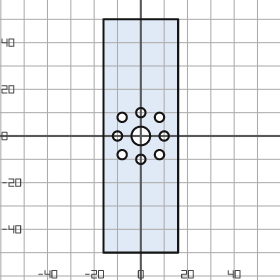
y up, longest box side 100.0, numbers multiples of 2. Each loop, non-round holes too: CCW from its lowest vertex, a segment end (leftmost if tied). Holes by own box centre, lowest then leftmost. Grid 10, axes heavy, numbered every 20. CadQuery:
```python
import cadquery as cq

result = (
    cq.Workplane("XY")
    .moveTo(-16.0, -50.0)
    .lineTo(16.0, -50.0)
    .lineTo(16.0, 50.0)
    .lineTo(-16.0, 50.0)
    .close()
    .moveTo(0.0, -10.0)
    .circle(2.0)
    .moveTo(-8.0, -8.0)
    .circle(2.0)
    .moveTo(8.0, -8.0)
    .circle(2.0)
    .moveTo(-10.0, 0.0)
    .circle(2.0)
    .moveTo(0.0, 0.0)
    .circle(4.0)
    .moveTo(10.0, 0.0)
    .circle(2.0)
    .moveTo(-8.0, 8.0)
    .circle(2.0)
    .moveTo(8.0, 8.0)
    .circle(2.0)
    .moveTo(0.0, 10.0)
    .circle(2.0)
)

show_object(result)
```